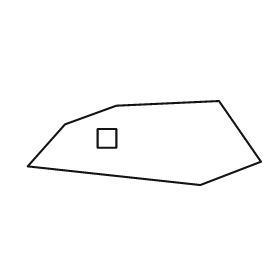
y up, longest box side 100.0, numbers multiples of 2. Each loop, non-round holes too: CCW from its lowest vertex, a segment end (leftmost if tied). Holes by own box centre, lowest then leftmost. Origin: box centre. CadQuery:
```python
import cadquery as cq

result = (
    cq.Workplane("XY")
    .moveTo(24.0, -18.0)
    .lineTo(50.0, -8.0)
    .lineTo(32.0, 18.0)
    .lineTo(-12.0, 16.0)
    .lineTo(-34.0, 8.0)
    .lineTo(-50.0, -10.0)
    .close()
    .moveTo(-20.0, -2.0)
    .lineTo(-12.0, -2.0)
    .lineTo(-12.0, 6.0)
    .lineTo(-20.0, 6.0)
    .close()
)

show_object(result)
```